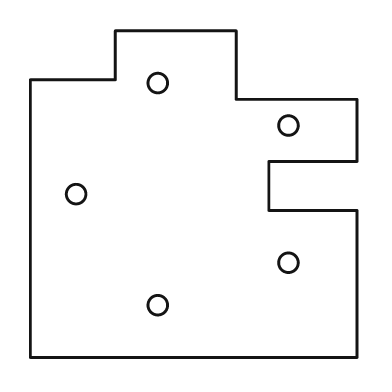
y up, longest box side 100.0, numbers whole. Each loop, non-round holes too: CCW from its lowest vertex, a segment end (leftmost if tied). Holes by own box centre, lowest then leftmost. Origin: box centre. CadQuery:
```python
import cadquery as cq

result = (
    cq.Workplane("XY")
    .moveTo(-50.0, -50.0)
    .lineTo(50.0, -50.0)
    .lineTo(50.0, -5.0)
    .lineTo(23.0, -5.0)
    .lineTo(23.0, 10.0)
    .lineTo(50.0, 10.0)
    .lineTo(50.0, 29.0)
    .lineTo(13.0, 29.0)
    .lineTo(13.0, 50.0)
    .lineTo(-24.0, 50.0)
    .lineTo(-24.0, 35.0)
    .lineTo(-50.0, 35.0)
    .close()
    .moveTo(-11.0, -34.0)
    .circle(3.0)
    .moveTo(29.0, -21.0)
    .circle(3.0)
    .moveTo(-36.0, 0.0)
    .circle(3.0)
    .moveTo(29.0, 21.0)
    .circle(3.0)
    .moveTo(-11.0, 34.0)
    .circle(3.0)
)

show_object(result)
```